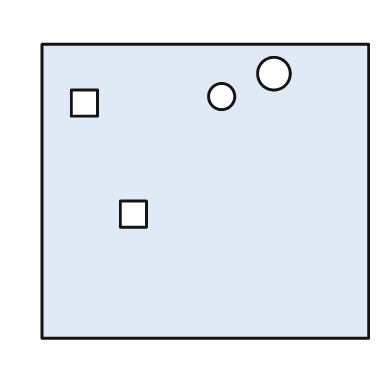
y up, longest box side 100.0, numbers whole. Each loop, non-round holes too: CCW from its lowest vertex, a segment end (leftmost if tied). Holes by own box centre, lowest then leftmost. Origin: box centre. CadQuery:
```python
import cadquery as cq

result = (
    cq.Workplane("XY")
    .moveTo(-50.0, -45.0)
    .lineTo(50.0, -45.0)
    .lineTo(50.0, 45.0)
    .lineTo(-50.0, 45.0)
    .close()
    .moveTo(-26.0, -11.0)
    .lineTo(-18.0, -11.0)
    .lineTo(-18.0, -3.0)
    .lineTo(-26.0, -3.0)
    .close()
    .moveTo(-41.0, 23.0)
    .lineTo(-33.0, 23.0)
    .lineTo(-33.0, 31.0)
    .lineTo(-41.0, 31.0)
    .close()
    .moveTo(5.0, 29.0)
    .circle(4.0)
    .moveTo(21.0, 36.0)
    .circle(5.0)
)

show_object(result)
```